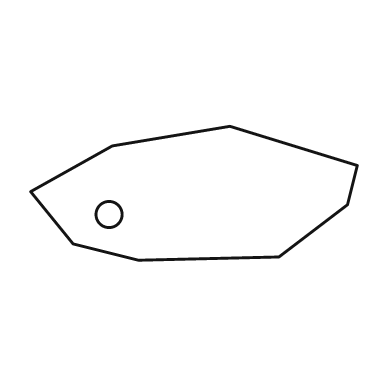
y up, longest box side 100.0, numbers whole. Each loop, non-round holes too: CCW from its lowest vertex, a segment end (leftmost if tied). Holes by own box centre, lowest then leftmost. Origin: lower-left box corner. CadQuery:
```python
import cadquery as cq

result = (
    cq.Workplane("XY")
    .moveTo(33.0, 0.0)
    .lineTo(76.0, 1.0)
    .lineTo(97.0, 17.0)
    .lineTo(100.0, 29.0)
    .lineTo(61.0, 41.0)
    .lineTo(25.0, 35.0)
    .lineTo(0.0, 21.0)
    .lineTo(13.0, 5.0)
    .close()
    .moveTo(24.0, 14.0)
    .circle(4.0)
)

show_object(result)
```